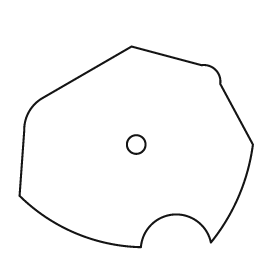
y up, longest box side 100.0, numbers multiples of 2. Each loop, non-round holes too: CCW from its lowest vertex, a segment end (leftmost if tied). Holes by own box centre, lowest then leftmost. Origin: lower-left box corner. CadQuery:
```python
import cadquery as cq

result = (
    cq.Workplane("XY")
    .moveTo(52.0, 0.0)
    .threePointArc((66.0, 14.0), (82.0, 2.0))
    .threePointArc((94.0, 22.0), (100.0, 44.0))
    .lineTo(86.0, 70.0)
    .threePointArc((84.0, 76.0), (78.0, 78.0))
    .lineTo(48.0, 86.0)
    .lineTo(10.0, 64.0)
    .threePointArc((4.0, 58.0), (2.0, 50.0))
    .lineTo(0.0, 22.0)
    .threePointArc((24.0, 6.0), (52.0, 0.0))
    .close()
    .moveTo(50.0, 44.0)
    .circle(4.0)
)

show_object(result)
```